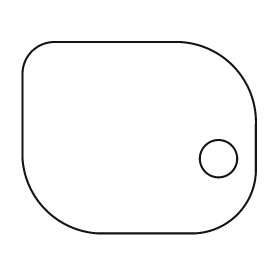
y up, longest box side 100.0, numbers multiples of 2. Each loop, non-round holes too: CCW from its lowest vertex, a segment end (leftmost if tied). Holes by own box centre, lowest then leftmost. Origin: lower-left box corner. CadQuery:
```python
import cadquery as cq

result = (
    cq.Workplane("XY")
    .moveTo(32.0, 0.0)
    .lineTo(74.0, 0.0)
    .threePointArc((92.0, 8.0), (100.0, 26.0))
    .lineTo(100.0, 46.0)
    .threePointArc((90.0, 72.0), (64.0, 82.0))
    .lineTo(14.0, 82.0)
    .threePointArc((4.0, 78.0), (0.0, 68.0))
    .lineTo(0.0, 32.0)
    .threePointArc((10.0, 10.0), (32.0, 0.0))
    .close()
    .moveTo(84.0, 32.0)
    .circle(8.0)
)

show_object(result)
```